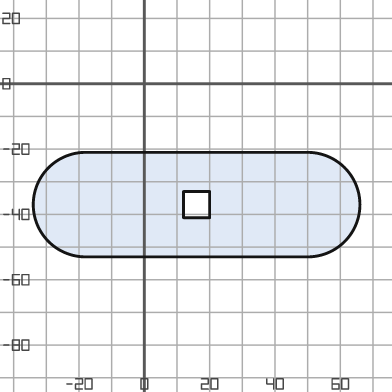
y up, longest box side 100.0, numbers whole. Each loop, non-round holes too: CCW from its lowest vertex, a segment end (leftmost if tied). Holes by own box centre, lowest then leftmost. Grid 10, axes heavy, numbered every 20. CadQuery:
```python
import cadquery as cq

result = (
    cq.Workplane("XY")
    .moveTo(-18.0, -53.0)
    .lineTo(50.0, -53.0)
    .threePointArc((66.0, -37.0), (50.0, -21.0))
    .lineTo(-18.0, -21.0)
    .threePointArc((-34.0, -37.0), (-18.0, -53.0))
    .close()
    .moveTo(12.0, -41.0)
    .lineTo(20.0, -41.0)
    .lineTo(20.0, -33.0)
    .lineTo(12.0, -33.0)
    .close()
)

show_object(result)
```